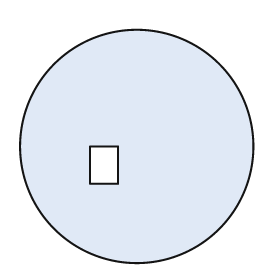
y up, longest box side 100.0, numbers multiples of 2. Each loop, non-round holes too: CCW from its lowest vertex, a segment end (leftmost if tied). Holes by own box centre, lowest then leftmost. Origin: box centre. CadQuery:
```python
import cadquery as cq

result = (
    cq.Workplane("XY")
    .moveTo(0.0, 0.0)
    .circle(50.0)
    .moveTo(-20.0, -16.0)
    .lineTo(-8.0, -16.0)
    .lineTo(-8.0, 0.0)
    .lineTo(-20.0, 0.0)
    .close()
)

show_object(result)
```